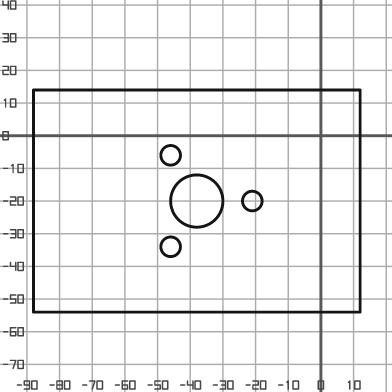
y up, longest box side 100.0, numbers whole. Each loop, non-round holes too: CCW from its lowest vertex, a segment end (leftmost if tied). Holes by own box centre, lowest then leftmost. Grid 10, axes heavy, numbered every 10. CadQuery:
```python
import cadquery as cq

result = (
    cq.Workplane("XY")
    .moveTo(-88.0, -54.0)
    .lineTo(12.0, -54.0)
    .lineTo(12.0, 14.0)
    .lineTo(-88.0, 14.0)
    .close()
    .moveTo(-46.0, -34.0)
    .circle(3.0)
    .moveTo(-38.0, -20.0)
    .circle(8.0)
    .moveTo(-21.0, -20.0)
    .circle(3.0)
    .moveTo(-46.0, -6.0)
    .circle(3.0)
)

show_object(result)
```